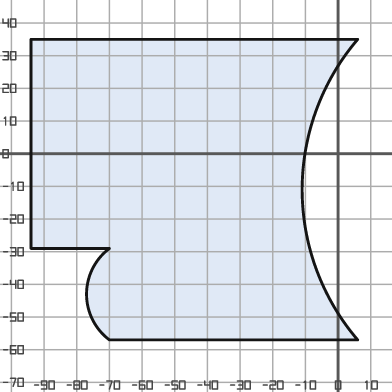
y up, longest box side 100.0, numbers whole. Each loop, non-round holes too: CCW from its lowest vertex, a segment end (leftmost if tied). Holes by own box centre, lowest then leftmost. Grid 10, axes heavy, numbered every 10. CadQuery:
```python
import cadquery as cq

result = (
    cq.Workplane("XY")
    .moveTo(-70.0, -57.0)
    .lineTo(6.0, -57.0)
    .threePointArc((-11.0, -11.0), (6.0, 35.0))
    .lineTo(-94.0, 35.0)
    .lineTo(-94.0, -29.0)
    .lineTo(-70.0, -29.0)
    .threePointArc((-77.0, -43.0), (-70.0, -57.0))
    .close()
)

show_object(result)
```